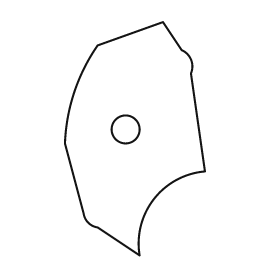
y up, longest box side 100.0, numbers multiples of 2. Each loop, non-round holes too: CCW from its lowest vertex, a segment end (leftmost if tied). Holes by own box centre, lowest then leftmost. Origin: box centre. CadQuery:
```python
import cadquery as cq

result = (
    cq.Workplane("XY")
    .moveTo(2.0, -50.0)
    .threePointArc((8.0, -26.0), (30.0, -14.0))
    .lineTo(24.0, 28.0)
    .threePointArc((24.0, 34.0), (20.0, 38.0))
    .lineTo(12.0, 50.0)
    .lineTo(-16.0, 40.0)
    .threePointArc((-26.0, 20.0), (-30.0, -2.0))
    .lineTo(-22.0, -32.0)
    .threePointArc((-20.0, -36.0), (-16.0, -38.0))
    .close()
    .moveTo(-4.0, 4.0)
    .circle(6.0)
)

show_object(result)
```